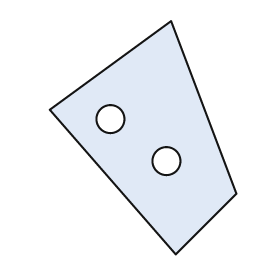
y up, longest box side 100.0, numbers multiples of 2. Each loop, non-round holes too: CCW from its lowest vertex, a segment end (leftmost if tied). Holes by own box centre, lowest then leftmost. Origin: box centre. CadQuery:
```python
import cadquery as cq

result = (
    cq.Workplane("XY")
    .moveTo(14.0, -50.0)
    .lineTo(40.0, -24.0)
    .lineTo(12.0, 50.0)
    .lineTo(-40.0, 12.0)
    .close()
    .moveTo(10.0, -10.0)
    .circle(6.0)
    .moveTo(-14.0, 8.0)
    .circle(6.0)
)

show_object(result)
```